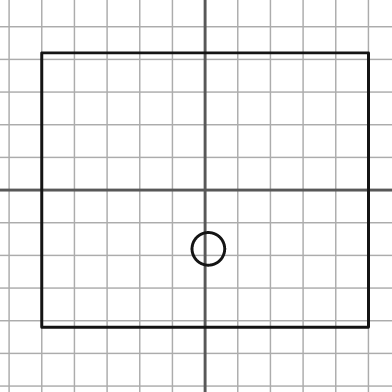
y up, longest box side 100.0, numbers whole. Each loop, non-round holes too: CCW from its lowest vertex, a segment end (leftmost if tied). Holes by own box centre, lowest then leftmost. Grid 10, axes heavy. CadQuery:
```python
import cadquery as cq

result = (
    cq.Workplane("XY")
    .moveTo(-50.0, -42.0)
    .lineTo(50.0, -42.0)
    .lineTo(50.0, 42.0)
    .lineTo(-50.0, 42.0)
    .close()
    .moveTo(1.0, -18.0)
    .circle(5.0)
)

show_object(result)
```